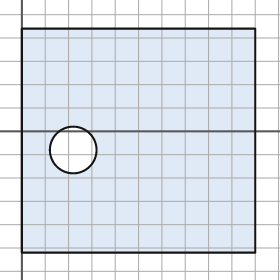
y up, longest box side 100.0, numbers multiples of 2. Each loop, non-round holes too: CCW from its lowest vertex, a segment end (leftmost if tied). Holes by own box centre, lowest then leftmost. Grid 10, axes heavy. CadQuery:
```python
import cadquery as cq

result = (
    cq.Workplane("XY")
    .moveTo(0.0, -52.0)
    .lineTo(100.0, -52.0)
    .lineTo(100.0, 44.0)
    .lineTo(0.0, 44.0)
    .close()
    .moveTo(22.0, -8.0)
    .circle(10.0)
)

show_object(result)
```